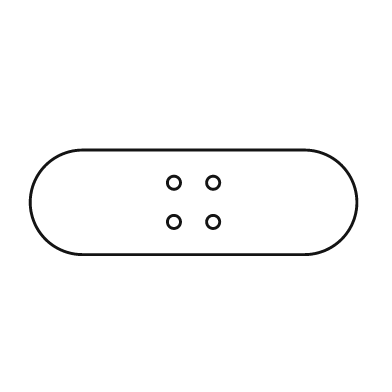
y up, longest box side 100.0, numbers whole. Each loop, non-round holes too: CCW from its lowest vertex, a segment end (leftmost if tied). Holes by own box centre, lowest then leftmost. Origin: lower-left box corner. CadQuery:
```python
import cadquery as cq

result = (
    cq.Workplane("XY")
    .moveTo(16.0, 0.0)
    .lineTo(84.0, 0.0)
    .threePointArc((100.0, 16.0), (84.0, 32.0))
    .lineTo(16.0, 32.0)
    .threePointArc((0.0, 16.0), (16.0, 0.0))
    .close()
    .moveTo(44.0, 10.0)
    .circle(2.0)
    .moveTo(56.0, 10.0)
    .circle(2.0)
    .moveTo(44.0, 22.0)
    .circle(2.0)
    .moveTo(56.0, 22.0)
    .circle(2.0)
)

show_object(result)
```